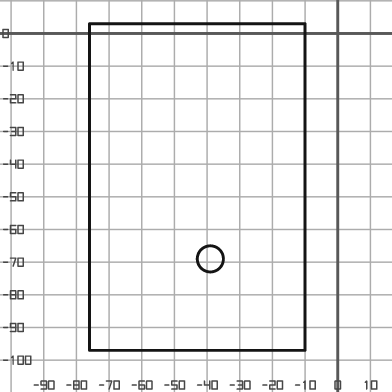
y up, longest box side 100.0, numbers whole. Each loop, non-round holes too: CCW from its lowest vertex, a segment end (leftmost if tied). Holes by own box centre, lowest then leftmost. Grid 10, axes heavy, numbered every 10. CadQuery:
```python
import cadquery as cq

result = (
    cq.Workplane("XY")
    .moveTo(-76.0, -97.0)
    .lineTo(-10.0, -97.0)
    .lineTo(-10.0, 3.0)
    .lineTo(-76.0, 3.0)
    .close()
    .moveTo(-39.0, -69.0)
    .circle(4.0)
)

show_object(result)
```